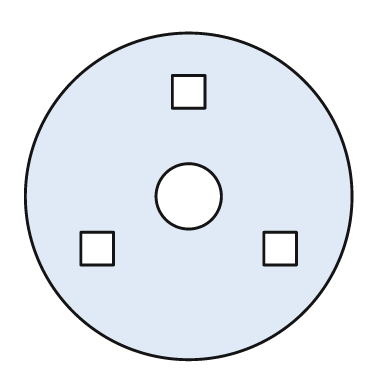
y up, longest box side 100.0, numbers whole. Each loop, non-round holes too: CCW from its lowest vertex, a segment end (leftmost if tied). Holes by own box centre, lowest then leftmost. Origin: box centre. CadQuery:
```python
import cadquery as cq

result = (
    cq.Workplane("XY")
    .moveTo(0.0, 0.0)
    .circle(50.0)
    .moveTo(-33.0, -21.0)
    .lineTo(-23.0, -21.0)
    .lineTo(-23.0, -11.0)
    .lineTo(-33.0, -11.0)
    .close()
    .moveTo(23.0, -21.0)
    .lineTo(33.0, -21.0)
    .lineTo(33.0, -11.0)
    .lineTo(23.0, -11.0)
    .close()
    .moveTo(0.0, 0.0)
    .circle(10.0)
    .moveTo(-5.0, 27.0)
    .lineTo(5.0, 27.0)
    .lineTo(5.0, 37.0)
    .lineTo(-5.0, 37.0)
    .close()
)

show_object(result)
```